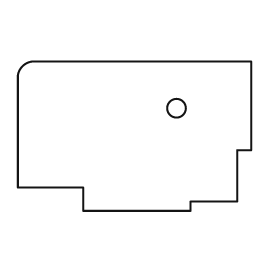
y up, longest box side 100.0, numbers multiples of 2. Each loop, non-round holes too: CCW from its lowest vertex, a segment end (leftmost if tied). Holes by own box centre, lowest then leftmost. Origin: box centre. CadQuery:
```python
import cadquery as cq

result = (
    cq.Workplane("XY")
    .moveTo(-22.0, -32.0)
    .lineTo(24.0, -32.0)
    .lineTo(24.0, -28.0)
    .lineTo(44.0, -28.0)
    .lineTo(44.0, -6.0)
    .lineTo(50.0, -6.0)
    .lineTo(50.0, 32.0)
    .lineTo(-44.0, 32.0)
    .threePointArc((-48.0, 30.0), (-50.0, 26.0))
    .lineTo(-50.0, -22.0)
    .lineTo(-22.0, -22.0)
    .close()
    .moveTo(18.0, 12.0)
    .circle(4.0)
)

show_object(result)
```